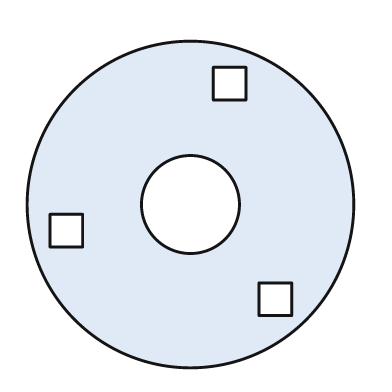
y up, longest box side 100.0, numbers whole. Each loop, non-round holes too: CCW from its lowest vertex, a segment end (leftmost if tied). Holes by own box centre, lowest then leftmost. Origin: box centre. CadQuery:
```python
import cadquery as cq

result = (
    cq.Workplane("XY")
    .moveTo(0.0, 0.0)
    .circle(50.0)
    .moveTo(21.0, -34.0)
    .lineTo(31.0, -34.0)
    .lineTo(31.0, -24.0)
    .lineTo(21.0, -24.0)
    .close()
    .moveTo(-43.0, -13.0)
    .lineTo(-33.0, -13.0)
    .lineTo(-33.0, -3.0)
    .lineTo(-43.0, -3.0)
    .close()
    .moveTo(0.0, 0.0)
    .circle(15.0)
    .moveTo(7.0, 32.0)
    .lineTo(17.0, 32.0)
    .lineTo(17.0, 42.0)
    .lineTo(7.0, 42.0)
    .close()
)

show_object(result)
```